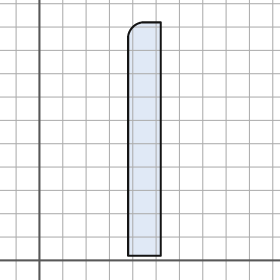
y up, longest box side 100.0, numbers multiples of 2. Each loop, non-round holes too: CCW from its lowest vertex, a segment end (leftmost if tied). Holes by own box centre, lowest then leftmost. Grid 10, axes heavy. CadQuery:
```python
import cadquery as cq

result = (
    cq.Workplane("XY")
    .moveTo(38.0, 2.0)
    .lineTo(52.0, 2.0)
    .lineTo(52.0, 102.0)
    .lineTo(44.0, 102.0)
    .threePointArc((40.0, 100.0), (38.0, 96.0))
    .close()
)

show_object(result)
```